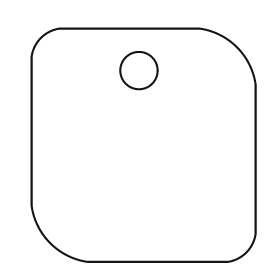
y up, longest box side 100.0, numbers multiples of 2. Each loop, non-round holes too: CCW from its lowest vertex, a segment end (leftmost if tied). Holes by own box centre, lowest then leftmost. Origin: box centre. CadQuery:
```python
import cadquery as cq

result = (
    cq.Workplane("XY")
    .moveTo(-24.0, -50.0)
    .lineTo(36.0, -50.0)
    .threePointArc((44.0, -46.0), (48.0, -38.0))
    .lineTo(48.0, 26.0)
    .threePointArc((40.0, 42.0), (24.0, 50.0))
    .lineTo(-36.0, 50.0)
    .threePointArc((-44.0, 46.0), (-48.0, 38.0))
    .lineTo(-48.0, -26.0)
    .threePointArc((-40.0, -42.0), (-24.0, -50.0))
    .close()
    .moveTo(-2.0, 32.0)
    .circle(8.0)
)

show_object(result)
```